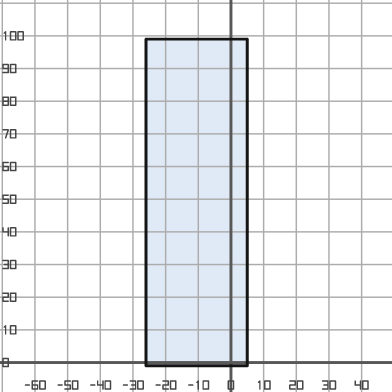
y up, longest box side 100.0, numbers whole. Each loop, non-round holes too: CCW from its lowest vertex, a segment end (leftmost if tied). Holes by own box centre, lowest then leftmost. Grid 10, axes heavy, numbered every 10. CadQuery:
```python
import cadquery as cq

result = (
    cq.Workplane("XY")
    .moveTo(-26.0, -1.0)
    .lineTo(5.0, -1.0)
    .lineTo(5.0, 99.0)
    .lineTo(-26.0, 99.0)
    .close()
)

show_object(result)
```